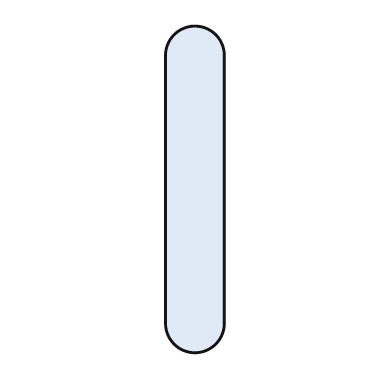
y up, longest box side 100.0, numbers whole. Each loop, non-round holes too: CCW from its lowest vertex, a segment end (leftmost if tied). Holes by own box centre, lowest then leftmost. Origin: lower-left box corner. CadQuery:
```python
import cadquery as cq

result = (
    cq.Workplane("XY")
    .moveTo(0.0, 9.0)
    .threePointArc((9.0, 0.0), (18.0, 9.0))
    .lineTo(18.0, 91.0)
    .threePointArc((9.0, 100.0), (0.0, 91.0))
    .close()
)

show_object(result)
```